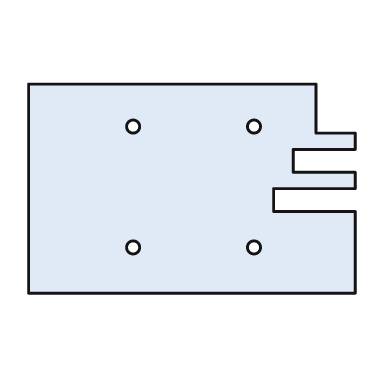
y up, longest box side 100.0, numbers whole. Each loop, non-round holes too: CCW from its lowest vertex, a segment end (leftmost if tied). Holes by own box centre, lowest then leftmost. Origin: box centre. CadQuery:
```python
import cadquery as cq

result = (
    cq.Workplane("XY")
    .moveTo(-50.0, -32.0)
    .lineTo(50.0, -32.0)
    .lineTo(50.0, -7.0)
    .lineTo(25.0, -7.0)
    .lineTo(25.0, 0.0)
    .lineTo(50.0, 0.0)
    .lineTo(50.0, 5.0)
    .lineTo(31.0, 5.0)
    .lineTo(31.0, 12.0)
    .lineTo(50.0, 12.0)
    .lineTo(50.0, 17.0)
    .lineTo(38.0, 17.0)
    .lineTo(38.0, 32.0)
    .lineTo(-50.0, 32.0)
    .close()
    .moveTo(-18.0, -18.0)
    .circle(2.0)
    .moveTo(19.0, -18.0)
    .circle(2.0)
    .moveTo(-18.0, 19.0)
    .circle(2.0)
    .moveTo(19.0, 19.0)
    .circle(2.0)
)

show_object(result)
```